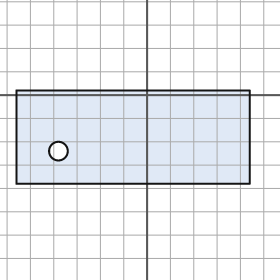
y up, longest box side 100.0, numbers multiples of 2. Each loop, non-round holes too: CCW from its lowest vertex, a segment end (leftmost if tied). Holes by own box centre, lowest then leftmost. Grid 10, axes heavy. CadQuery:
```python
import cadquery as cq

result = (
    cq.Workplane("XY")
    .moveTo(-56.0, -38.0)
    .lineTo(44.0, -38.0)
    .lineTo(44.0, 2.0)
    .lineTo(-56.0, 2.0)
    .close()
    .moveTo(-38.0, -24.0)
    .circle(4.0)
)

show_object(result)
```